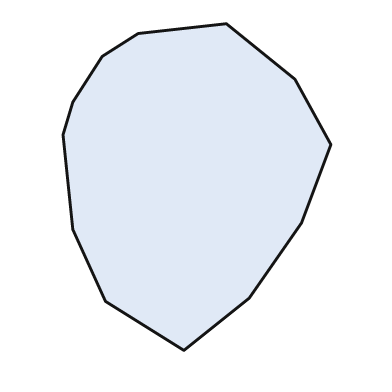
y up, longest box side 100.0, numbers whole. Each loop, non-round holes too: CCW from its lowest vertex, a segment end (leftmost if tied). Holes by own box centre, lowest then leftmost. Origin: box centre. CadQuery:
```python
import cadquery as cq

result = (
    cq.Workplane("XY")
    .moveTo(-4.0, -50.0)
    .lineTo(16.0, -34.0)
    .lineTo(32.0, -11.0)
    .lineTo(41.0, 13.0)
    .lineTo(30.0, 33.0)
    .lineTo(9.0, 50.0)
    .lineTo(-18.0, 47.0)
    .lineTo(-29.0, 40.0)
    .lineTo(-38.0, 26.0)
    .lineTo(-41.0, 16.0)
    .lineTo(-38.0, -13.0)
    .lineTo(-28.0, -35.0)
    .close()
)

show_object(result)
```